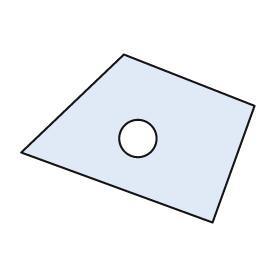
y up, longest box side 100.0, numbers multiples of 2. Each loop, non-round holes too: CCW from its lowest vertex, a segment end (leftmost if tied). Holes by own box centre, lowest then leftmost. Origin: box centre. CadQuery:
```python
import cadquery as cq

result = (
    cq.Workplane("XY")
    .moveTo(32.0, -36.0)
    .lineTo(50.0, 14.0)
    .lineTo(-6.0, 36.0)
    .lineTo(-50.0, -6.0)
    .close()
    .moveTo(0.0, 0.0)
    .circle(8.0)
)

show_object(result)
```